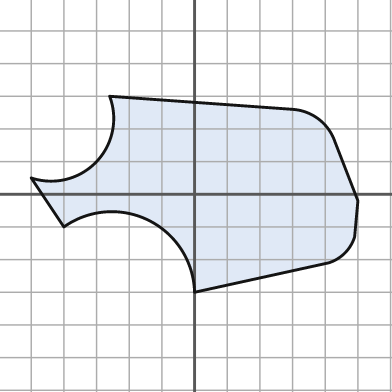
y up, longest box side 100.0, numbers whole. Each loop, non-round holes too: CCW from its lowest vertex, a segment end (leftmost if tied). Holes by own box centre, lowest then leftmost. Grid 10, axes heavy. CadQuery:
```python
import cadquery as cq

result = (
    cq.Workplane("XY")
    .moveTo(0.0, -30.0)
    .lineTo(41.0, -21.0)
    .threePointArc((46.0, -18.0), (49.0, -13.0))
    .lineTo(50.0, -2.0)
    .lineTo(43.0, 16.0)
    .threePointArc((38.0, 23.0), (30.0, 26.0))
    .lineTo(-26.0, 30.0)
    .threePointArc((-30.0, 10.0), (-50.0, 5.0))
    .lineTo(-40.0, -10.0)
    .threePointArc((-14.0, -8.0), (0.0, -30.0))
    .close()
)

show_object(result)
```